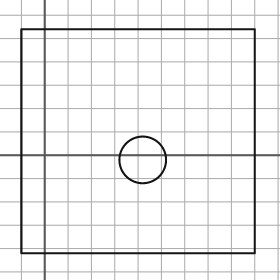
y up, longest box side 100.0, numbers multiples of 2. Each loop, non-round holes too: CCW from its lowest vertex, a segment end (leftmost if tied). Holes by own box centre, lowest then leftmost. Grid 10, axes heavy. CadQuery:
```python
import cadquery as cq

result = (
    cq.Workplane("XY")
    .moveTo(-10.0, -42.0)
    .lineTo(90.0, -42.0)
    .lineTo(90.0, 54.0)
    .lineTo(-10.0, 54.0)
    .close()
    .moveTo(42.0, -2.0)
    .circle(10.0)
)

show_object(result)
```